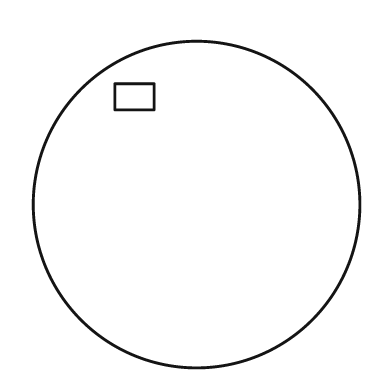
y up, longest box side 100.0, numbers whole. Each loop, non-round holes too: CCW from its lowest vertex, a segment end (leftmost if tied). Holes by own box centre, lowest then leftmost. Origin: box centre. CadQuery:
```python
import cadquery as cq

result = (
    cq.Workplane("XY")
    .moveTo(0.0, 0.0)
    .circle(50.0)
    .moveTo(-25.0, 29.0)
    .lineTo(-13.0, 29.0)
    .lineTo(-13.0, 37.0)
    .lineTo(-25.0, 37.0)
    .close()
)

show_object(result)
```